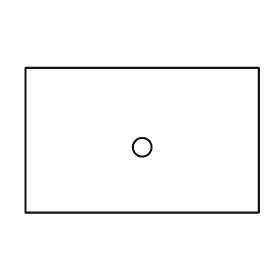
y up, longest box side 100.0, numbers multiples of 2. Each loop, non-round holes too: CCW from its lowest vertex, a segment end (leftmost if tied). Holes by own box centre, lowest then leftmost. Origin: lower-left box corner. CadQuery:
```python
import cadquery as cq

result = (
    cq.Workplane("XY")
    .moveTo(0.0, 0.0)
    .lineTo(100.0, 0.0)
    .lineTo(100.0, 62.0)
    .lineTo(0.0, 62.0)
    .close()
    .moveTo(50.0, 28.0)
    .circle(4.0)
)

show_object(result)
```